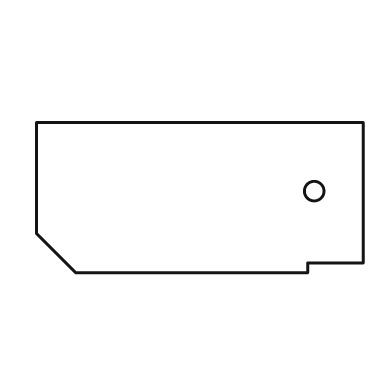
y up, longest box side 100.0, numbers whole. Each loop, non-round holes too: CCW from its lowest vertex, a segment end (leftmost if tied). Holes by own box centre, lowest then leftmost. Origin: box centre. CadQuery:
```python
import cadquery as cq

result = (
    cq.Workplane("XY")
    .moveTo(-38.0, -23.0)
    .lineTo(33.0, -23.0)
    .lineTo(33.0, -20.0)
    .lineTo(50.0, -20.0)
    .lineTo(50.0, 23.0)
    .lineTo(-50.0, 23.0)
    .lineTo(-50.0, -11.0)
    .close()
    .moveTo(35.0, 2.0)
    .circle(3.0)
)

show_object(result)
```